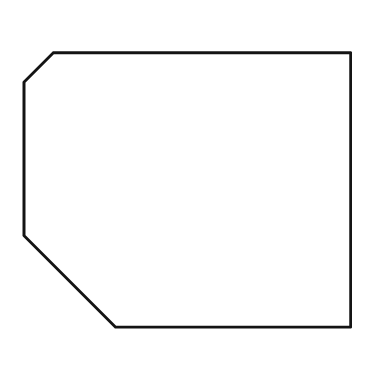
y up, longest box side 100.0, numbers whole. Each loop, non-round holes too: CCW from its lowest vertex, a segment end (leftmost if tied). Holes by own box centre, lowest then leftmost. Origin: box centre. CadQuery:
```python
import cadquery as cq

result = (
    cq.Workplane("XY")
    .moveTo(-22.0, -42.0)
    .lineTo(50.0, -42.0)
    .lineTo(50.0, 42.0)
    .lineTo(-41.0, 42.0)
    .lineTo(-50.0, 33.0)
    .lineTo(-50.0, -14.0)
    .close()
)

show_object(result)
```